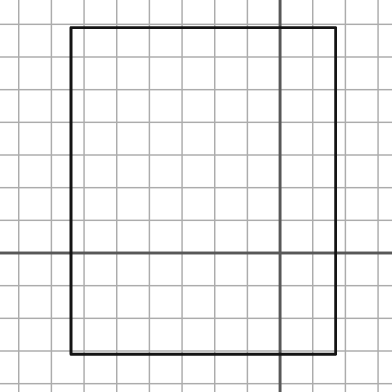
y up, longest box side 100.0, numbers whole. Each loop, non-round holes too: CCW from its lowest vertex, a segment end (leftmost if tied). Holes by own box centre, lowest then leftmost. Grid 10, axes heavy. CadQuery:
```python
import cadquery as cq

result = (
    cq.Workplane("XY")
    .moveTo(-64.0, -31.0)
    .lineTo(17.0, -31.0)
    .lineTo(17.0, 69.0)
    .lineTo(-64.0, 69.0)
    .close()
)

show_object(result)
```